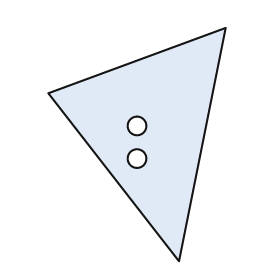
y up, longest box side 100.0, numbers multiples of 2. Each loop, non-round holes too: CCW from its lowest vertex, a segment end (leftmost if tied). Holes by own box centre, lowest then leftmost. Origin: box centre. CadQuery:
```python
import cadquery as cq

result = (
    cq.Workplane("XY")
    .moveTo(18.0, -50.0)
    .lineTo(38.0, 50.0)
    .lineTo(-38.0, 22.0)
    .close()
    .moveTo(0.0, -6.0)
    .circle(4.0)
    .moveTo(0.0, 8.0)
    .circle(4.0)
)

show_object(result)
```